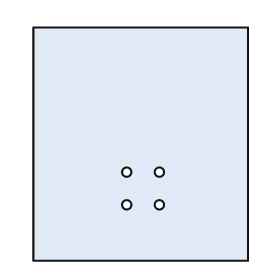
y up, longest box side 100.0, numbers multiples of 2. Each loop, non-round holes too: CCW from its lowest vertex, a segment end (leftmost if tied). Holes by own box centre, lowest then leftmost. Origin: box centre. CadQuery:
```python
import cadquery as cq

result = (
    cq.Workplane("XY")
    .moveTo(-46.0, -50.0)
    .lineTo(46.0, -50.0)
    .lineTo(46.0, 50.0)
    .lineTo(-46.0, 50.0)
    .close()
    .moveTo(-6.0, -26.0)
    .circle(2.0)
    .moveTo(8.0, -26.0)
    .circle(2.0)
    .moveTo(-6.0, -12.0)
    .circle(2.0)
    .moveTo(8.0, -12.0)
    .circle(2.0)
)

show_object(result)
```